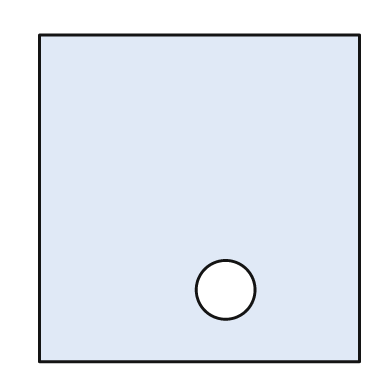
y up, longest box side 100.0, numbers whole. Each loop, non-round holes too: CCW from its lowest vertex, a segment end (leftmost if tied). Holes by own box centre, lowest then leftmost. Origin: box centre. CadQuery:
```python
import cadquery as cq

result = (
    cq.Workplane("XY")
    .moveTo(-49.0, -50.0)
    .lineTo(49.0, -50.0)
    .lineTo(49.0, 50.0)
    .lineTo(-49.0, 50.0)
    .close()
    .moveTo(8.0, -28.0)
    .circle(9.0)
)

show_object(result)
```